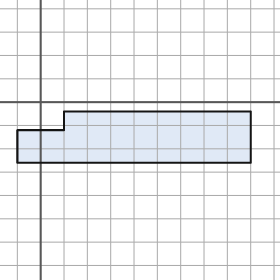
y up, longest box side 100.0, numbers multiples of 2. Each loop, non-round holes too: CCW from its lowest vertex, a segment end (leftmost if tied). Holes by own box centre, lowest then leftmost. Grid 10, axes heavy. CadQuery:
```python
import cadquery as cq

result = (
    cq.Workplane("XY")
    .moveTo(-10.0, -26.0)
    .lineTo(90.0, -26.0)
    .lineTo(90.0, -4.0)
    .lineTo(10.0, -4.0)
    .lineTo(10.0, -12.0)
    .lineTo(-10.0, -12.0)
    .close()
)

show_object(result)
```